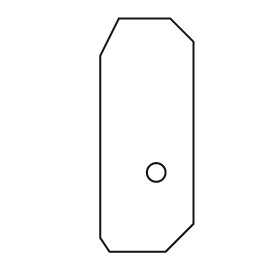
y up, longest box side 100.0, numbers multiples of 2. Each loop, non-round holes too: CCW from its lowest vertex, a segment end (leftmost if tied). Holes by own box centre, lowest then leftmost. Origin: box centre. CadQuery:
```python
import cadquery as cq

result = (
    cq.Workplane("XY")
    .moveTo(-16.0, -50.0)
    .lineTo(8.0, -50.0)
    .lineTo(20.0, -38.0)
    .lineTo(20.0, 40.0)
    .lineTo(10.0, 50.0)
    .lineTo(-12.0, 50.0)
    .lineTo(-20.0, 34.0)
    .lineTo(-20.0, -44.0)
    .close()
    .moveTo(4.0, -16.0)
    .circle(4.0)
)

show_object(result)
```